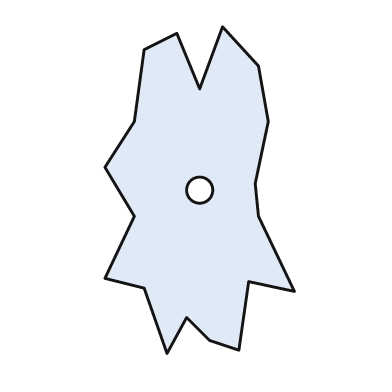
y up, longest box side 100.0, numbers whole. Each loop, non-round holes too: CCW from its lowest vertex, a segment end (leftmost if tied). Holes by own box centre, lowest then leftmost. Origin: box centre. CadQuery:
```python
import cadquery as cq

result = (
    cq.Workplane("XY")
    .moveTo(-10.0, -50.0)
    .lineTo(-4.0, -39.0)
    .lineTo(3.0, -46.0)
    .lineTo(12.0, -49.0)
    .lineTo(15.0, -28.0)
    .lineTo(29.0, -31.0)
    .lineTo(18.0, -8.0)
    .lineTo(17.0, 2.0)
    .lineTo(21.0, 21.0)
    .lineTo(18.0, 38.0)
    .lineTo(7.0, 50.0)
    .lineTo(0.0, 31.0)
    .lineTo(-7.0, 48.0)
    .lineTo(-17.0, 43.0)
    .lineTo(-20.0, 21.0)
    .lineTo(-29.0, 7.0)
    .lineTo(-20.0, -8.0)
    .lineTo(-29.0, -27.0)
    .lineTo(-17.0, -30.0)
    .close()
    .moveTo(0.0, 0.0)
    .circle(4.0)
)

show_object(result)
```